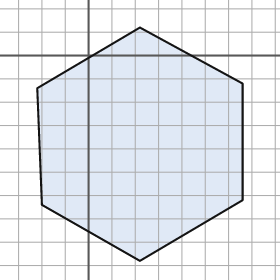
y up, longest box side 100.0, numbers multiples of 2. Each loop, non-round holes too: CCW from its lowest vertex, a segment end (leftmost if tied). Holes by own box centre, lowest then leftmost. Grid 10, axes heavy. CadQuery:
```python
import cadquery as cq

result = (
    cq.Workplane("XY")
    .moveTo(22.0, -88.0)
    .lineTo(66.0, -62.0)
    .lineTo(66.0, -12.0)
    .lineTo(22.0, 12.0)
    .lineTo(-22.0, -14.0)
    .lineTo(-20.0, -64.0)
    .close()
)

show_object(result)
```